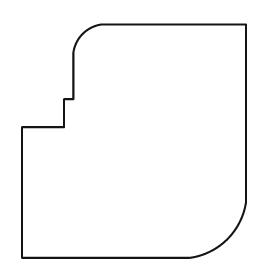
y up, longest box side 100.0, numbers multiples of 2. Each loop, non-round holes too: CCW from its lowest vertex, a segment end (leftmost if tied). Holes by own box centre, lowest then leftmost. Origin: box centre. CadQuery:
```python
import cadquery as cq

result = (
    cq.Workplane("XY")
    .moveTo(-48.0, -50.0)
    .lineTo(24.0, -50.0)
    .threePointArc((40.0, -42.0), (48.0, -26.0))
    .lineTo(48.0, 50.0)
    .lineTo(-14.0, 50.0)
    .threePointArc((-22.0, 46.0), (-26.0, 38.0))
    .lineTo(-26.0, 18.0)
    .lineTo(-30.0, 18.0)
    .lineTo(-30.0, 6.0)
    .lineTo(-48.0, 6.0)
    .close()
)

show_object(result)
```